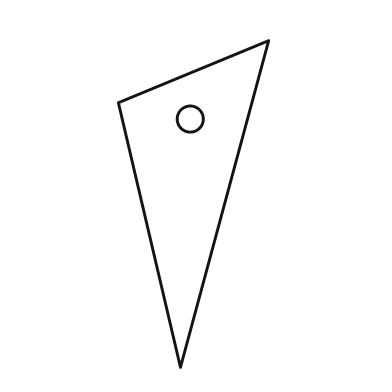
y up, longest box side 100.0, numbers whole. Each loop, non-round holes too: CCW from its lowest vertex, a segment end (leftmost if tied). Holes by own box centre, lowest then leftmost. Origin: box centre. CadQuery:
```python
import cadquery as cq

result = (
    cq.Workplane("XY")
    .moveTo(-4.0, -50.0)
    .lineTo(23.0, 50.0)
    .lineTo(-23.0, 31.0)
    .close()
    .moveTo(-1.0, 26.0)
    .circle(4.0)
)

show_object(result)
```